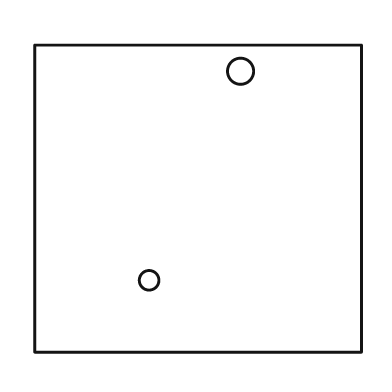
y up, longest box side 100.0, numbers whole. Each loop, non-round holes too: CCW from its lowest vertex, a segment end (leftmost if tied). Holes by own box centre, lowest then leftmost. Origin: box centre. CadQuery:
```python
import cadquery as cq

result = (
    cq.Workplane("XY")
    .moveTo(-50.0, -47.0)
    .lineTo(50.0, -47.0)
    .lineTo(50.0, 47.0)
    .lineTo(-50.0, 47.0)
    .close()
    .moveTo(-15.0, -25.0)
    .circle(3.0)
    .moveTo(13.0, 39.0)
    .circle(4.0)
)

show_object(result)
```